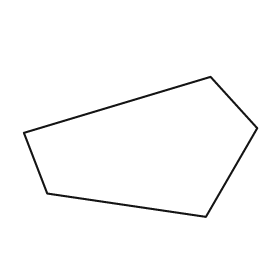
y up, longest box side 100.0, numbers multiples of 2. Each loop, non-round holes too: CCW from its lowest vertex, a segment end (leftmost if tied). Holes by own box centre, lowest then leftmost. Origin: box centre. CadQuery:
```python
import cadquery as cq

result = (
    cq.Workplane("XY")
    .moveTo(28.0, -30.0)
    .lineTo(50.0, 8.0)
    .lineTo(30.0, 30.0)
    .lineTo(-50.0, 6.0)
    .lineTo(-40.0, -20.0)
    .close()
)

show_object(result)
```